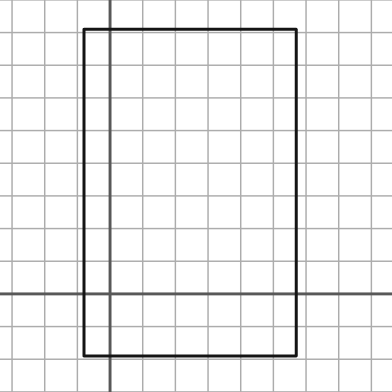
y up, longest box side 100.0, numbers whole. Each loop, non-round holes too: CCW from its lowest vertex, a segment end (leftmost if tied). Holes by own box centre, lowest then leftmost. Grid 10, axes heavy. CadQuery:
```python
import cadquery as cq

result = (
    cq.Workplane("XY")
    .moveTo(-8.0, -19.0)
    .lineTo(57.0, -19.0)
    .lineTo(57.0, 81.0)
    .lineTo(-8.0, 81.0)
    .close()
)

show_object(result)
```